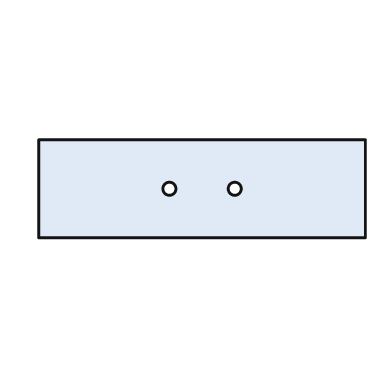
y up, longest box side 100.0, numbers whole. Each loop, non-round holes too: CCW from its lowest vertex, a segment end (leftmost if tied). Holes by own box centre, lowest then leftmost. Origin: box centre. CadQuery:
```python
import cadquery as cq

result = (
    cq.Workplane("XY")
    .moveTo(-50.0, -15.0)
    .lineTo(50.0, -15.0)
    .lineTo(50.0, 15.0)
    .lineTo(-50.0, 15.0)
    .close()
    .moveTo(-10.0, 0.0)
    .circle(2.0)
    .moveTo(10.0, 0.0)
    .circle(2.0)
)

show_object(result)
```